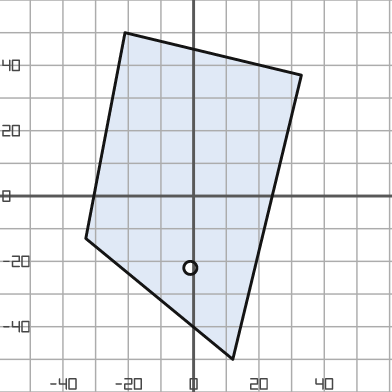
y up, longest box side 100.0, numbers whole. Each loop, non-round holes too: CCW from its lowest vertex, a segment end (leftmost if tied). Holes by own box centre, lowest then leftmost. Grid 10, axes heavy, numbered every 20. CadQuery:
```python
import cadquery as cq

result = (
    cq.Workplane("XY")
    .moveTo(12.0, -50.0)
    .lineTo(33.0, 37.0)
    .lineTo(-21.0, 50.0)
    .lineTo(-33.0, -13.0)
    .close()
    .moveTo(-1.0, -22.0)
    .circle(2.0)
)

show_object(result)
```